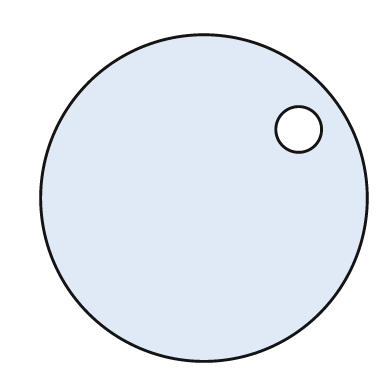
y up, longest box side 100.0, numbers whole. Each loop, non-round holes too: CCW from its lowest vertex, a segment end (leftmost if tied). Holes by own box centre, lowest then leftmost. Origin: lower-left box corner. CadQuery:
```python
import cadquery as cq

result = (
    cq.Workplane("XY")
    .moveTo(50.0, 50.0)
    .circle(50.0)
    .moveTo(79.0, 71.0)
    .circle(7.0)
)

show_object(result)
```